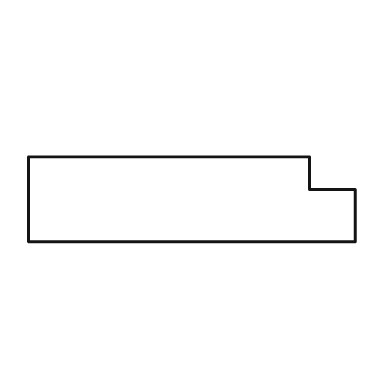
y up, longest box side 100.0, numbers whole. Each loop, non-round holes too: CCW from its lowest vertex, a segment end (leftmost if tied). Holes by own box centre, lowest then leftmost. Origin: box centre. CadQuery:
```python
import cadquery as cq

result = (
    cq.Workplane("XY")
    .moveTo(-50.0, -13.0)
    .lineTo(50.0, -13.0)
    .lineTo(50.0, 3.0)
    .lineTo(36.0, 3.0)
    .lineTo(36.0, 13.0)
    .lineTo(-50.0, 13.0)
    .close()
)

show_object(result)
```